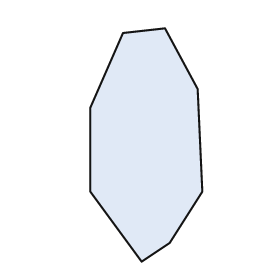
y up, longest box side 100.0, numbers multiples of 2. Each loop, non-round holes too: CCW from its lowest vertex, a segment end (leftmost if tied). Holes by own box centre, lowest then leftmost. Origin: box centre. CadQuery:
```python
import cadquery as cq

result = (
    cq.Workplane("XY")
    .moveTo(-2.0, -50.0)
    .lineTo(10.0, -42.0)
    .lineTo(24.0, -20.0)
    .lineTo(22.0, 24.0)
    .lineTo(8.0, 50.0)
    .lineTo(-10.0, 48.0)
    .lineTo(-24.0, 16.0)
    .lineTo(-24.0, -20.0)
    .close()
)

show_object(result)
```